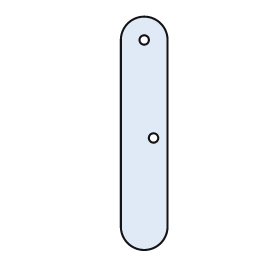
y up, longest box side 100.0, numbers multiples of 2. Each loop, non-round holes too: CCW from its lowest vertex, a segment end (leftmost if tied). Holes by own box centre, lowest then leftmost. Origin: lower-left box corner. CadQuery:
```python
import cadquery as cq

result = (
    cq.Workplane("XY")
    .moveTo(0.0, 10.0)
    .threePointArc((10.0, 0.0), (20.0, 10.0))
    .lineTo(20.0, 90.0)
    .threePointArc((10.0, 100.0), (0.0, 90.0))
    .close()
    .moveTo(14.0, 48.0)
    .circle(2.0)
    .moveTo(10.0, 90.0)
    .circle(2.0)
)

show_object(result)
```